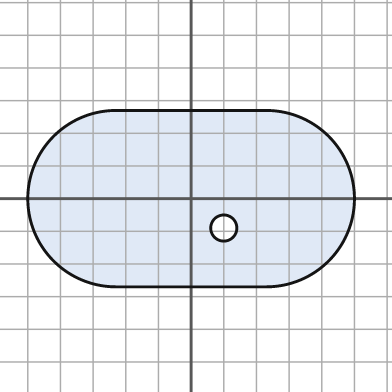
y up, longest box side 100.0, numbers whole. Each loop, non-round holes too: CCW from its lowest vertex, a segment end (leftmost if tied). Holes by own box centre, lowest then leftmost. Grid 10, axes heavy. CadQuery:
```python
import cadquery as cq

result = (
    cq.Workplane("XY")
    .moveTo(-23.0, -27.0)
    .lineTo(23.0, -27.0)
    .threePointArc((50.0, 0.0), (23.0, 27.0))
    .lineTo(-23.0, 27.0)
    .threePointArc((-50.0, 0.0), (-23.0, -27.0))
    .close()
    .moveTo(10.0, -9.0)
    .circle(4.0)
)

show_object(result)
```